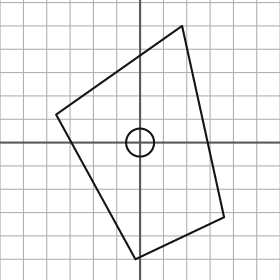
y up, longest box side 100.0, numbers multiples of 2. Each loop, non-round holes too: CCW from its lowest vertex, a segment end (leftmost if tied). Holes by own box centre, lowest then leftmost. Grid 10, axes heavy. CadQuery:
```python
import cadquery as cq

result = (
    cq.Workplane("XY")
    .moveTo(-2.0, -50.0)
    .lineTo(36.0, -32.0)
    .lineTo(18.0, 50.0)
    .lineTo(-36.0, 12.0)
    .close()
    .moveTo(0.0, 0.0)
    .circle(6.0)
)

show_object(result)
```